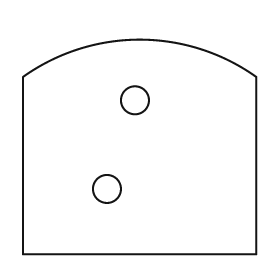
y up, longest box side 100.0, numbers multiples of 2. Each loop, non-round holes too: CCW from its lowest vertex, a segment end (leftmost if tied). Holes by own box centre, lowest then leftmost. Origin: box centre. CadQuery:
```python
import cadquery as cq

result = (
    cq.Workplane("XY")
    .moveTo(-50.0, -46.0)
    .lineTo(50.0, -46.0)
    .lineTo(50.0, 30.0)
    .threePointArc((0.0, 46.0), (-50.0, 30.0))
    .close()
    .moveTo(-14.0, -18.0)
    .circle(6.0)
    .moveTo(-2.0, 20.0)
    .circle(6.0)
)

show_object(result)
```